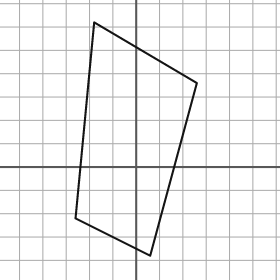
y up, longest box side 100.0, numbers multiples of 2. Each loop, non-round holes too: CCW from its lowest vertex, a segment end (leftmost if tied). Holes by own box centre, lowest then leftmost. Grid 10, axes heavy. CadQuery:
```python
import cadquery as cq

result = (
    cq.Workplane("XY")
    .moveTo(6.0, -38.0)
    .lineTo(26.0, 36.0)
    .lineTo(-18.0, 62.0)
    .lineTo(-26.0, -22.0)
    .close()
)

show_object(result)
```